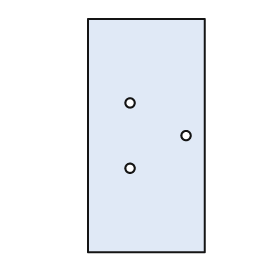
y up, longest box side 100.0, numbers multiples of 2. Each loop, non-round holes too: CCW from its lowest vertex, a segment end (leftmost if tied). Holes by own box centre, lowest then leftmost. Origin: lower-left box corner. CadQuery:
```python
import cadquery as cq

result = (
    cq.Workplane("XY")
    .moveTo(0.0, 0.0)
    .lineTo(50.0, 0.0)
    .lineTo(50.0, 100.0)
    .lineTo(0.0, 100.0)
    .close()
    .moveTo(18.0, 36.0)
    .circle(2.0)
    .moveTo(42.0, 50.0)
    .circle(2.0)
    .moveTo(18.0, 64.0)
    .circle(2.0)
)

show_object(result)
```